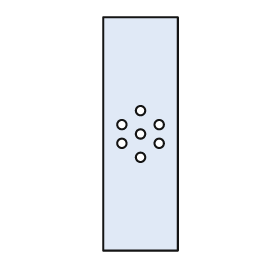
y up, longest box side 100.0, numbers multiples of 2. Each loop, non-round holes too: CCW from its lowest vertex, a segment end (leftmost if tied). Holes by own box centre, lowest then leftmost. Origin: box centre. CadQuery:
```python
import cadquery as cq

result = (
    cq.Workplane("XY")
    .moveTo(-16.0, -50.0)
    .lineTo(16.0, -50.0)
    .lineTo(16.0, 50.0)
    .lineTo(-16.0, 50.0)
    .close()
    .moveTo(0.0, -10.0)
    .circle(2.0)
    .moveTo(-8.0, -4.0)
    .circle(2.0)
    .moveTo(8.0, -4.0)
    .circle(2.0)
    .moveTo(0.0, 0.0)
    .circle(2.0)
    .moveTo(-8.0, 4.0)
    .circle(2.0)
    .moveTo(8.0, 4.0)
    .circle(2.0)
    .moveTo(0.0, 10.0)
    .circle(2.0)
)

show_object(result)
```